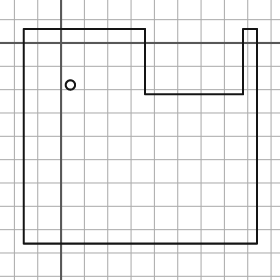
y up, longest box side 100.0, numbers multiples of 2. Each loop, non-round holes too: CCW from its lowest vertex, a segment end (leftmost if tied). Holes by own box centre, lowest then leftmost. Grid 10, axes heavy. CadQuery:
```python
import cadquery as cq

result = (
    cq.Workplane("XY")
    .moveTo(-16.0, -86.0)
    .lineTo(84.0, -86.0)
    .lineTo(84.0, 6.0)
    .lineTo(78.0, 6.0)
    .lineTo(78.0, -22.0)
    .lineTo(36.0, -22.0)
    .lineTo(36.0, 6.0)
    .lineTo(-16.0, 6.0)
    .close()
    .moveTo(4.0, -18.0)
    .circle(2.0)
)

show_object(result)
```